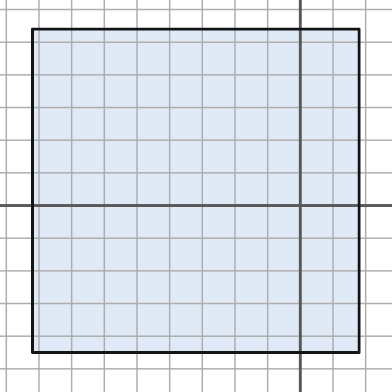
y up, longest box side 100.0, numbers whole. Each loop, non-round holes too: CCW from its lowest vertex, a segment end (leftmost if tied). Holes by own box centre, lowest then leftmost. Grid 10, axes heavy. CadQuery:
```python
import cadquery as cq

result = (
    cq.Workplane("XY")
    .moveTo(-82.0, -45.0)
    .lineTo(18.0, -45.0)
    .lineTo(18.0, 54.0)
    .lineTo(-82.0, 54.0)
    .close()
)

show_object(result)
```